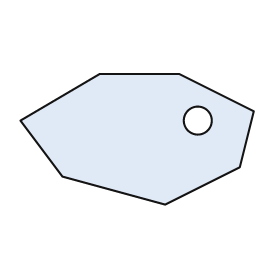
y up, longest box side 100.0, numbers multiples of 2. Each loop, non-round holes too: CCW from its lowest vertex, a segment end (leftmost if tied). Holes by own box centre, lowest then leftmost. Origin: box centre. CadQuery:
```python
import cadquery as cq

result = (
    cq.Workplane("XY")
    .moveTo(12.0, -28.0)
    .lineTo(44.0, -12.0)
    .lineTo(50.0, 12.0)
    .lineTo(18.0, 28.0)
    .lineTo(-16.0, 28.0)
    .lineTo(-50.0, 8.0)
    .lineTo(-32.0, -16.0)
    .close()
    .moveTo(26.0, 8.0)
    .circle(6.0)
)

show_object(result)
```